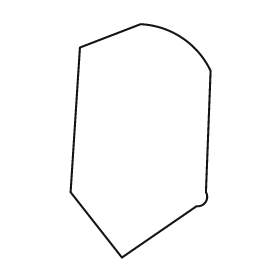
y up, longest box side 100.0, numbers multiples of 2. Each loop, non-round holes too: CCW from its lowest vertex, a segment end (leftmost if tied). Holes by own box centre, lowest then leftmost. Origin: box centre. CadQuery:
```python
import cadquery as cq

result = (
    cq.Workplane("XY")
    .moveTo(-8.0, -50.0)
    .lineTo(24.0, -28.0)
    .threePointArc((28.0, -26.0), (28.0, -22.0))
    .lineTo(30.0, 30.0)
    .threePointArc((18.0, 44.0), (0.0, 50.0))
    .lineTo(-26.0, 40.0)
    .lineTo(-30.0, -22.0)
    .close()
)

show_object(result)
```